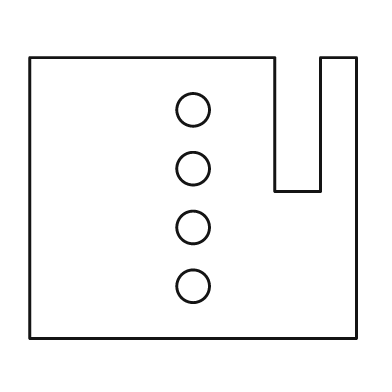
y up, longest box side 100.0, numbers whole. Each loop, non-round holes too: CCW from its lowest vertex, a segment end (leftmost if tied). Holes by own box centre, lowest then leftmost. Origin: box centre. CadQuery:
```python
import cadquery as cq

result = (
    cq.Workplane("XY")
    .moveTo(-50.0, -43.0)
    .lineTo(50.0, -43.0)
    .lineTo(50.0, 43.0)
    .lineTo(39.0, 43.0)
    .lineTo(39.0, 2.0)
    .lineTo(25.0, 2.0)
    .lineTo(25.0, 43.0)
    .lineTo(-50.0, 43.0)
    .close()
    .moveTo(0.0, -27.0)
    .circle(5.0)
    .moveTo(0.0, -9.0)
    .circle(5.0)
    .moveTo(0.0, 9.0)
    .circle(5.0)
    .moveTo(0.0, 27.0)
    .circle(5.0)
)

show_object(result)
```